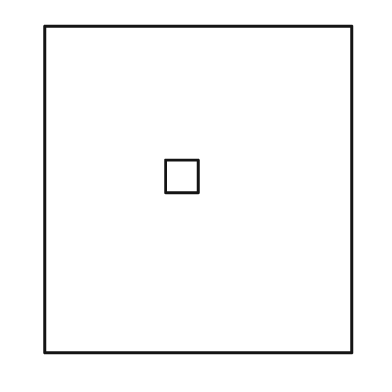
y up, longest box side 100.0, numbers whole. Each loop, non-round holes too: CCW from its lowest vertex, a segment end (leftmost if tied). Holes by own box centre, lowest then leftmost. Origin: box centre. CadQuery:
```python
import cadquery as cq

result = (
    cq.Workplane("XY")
    .moveTo(-47.0, -50.0)
    .lineTo(47.0, -50.0)
    .lineTo(47.0, 50.0)
    .lineTo(-47.0, 50.0)
    .close()
    .moveTo(-10.0, -1.0)
    .lineTo(0.0, -1.0)
    .lineTo(0.0, 9.0)
    .lineTo(-10.0, 9.0)
    .close()
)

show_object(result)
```